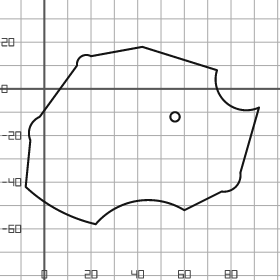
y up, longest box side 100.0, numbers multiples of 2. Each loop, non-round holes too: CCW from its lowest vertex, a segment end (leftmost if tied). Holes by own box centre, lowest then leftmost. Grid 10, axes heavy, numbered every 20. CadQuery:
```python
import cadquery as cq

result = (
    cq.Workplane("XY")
    .moveTo(22.0, -58.0)
    .threePointArc((40.0, -48.0), (60.0, -52.0))
    .lineTo(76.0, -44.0)
    .threePointArc((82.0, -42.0), (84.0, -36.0))
    .lineTo(92.0, -8.0)
    .threePointArc((78.0, -6.0), (74.0, 8.0))
    .lineTo(42.0, 18.0)
    .lineTo(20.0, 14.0)
    .threePointArc((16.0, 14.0), (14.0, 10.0))
    .lineTo(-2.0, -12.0)
    .threePointArc((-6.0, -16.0), (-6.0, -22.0))
    .lineTo(-8.0, -42.0)
    .threePointArc((6.0, -52.0), (22.0, -58.0))
    .close()
    .moveTo(56.0, -12.0)
    .circle(2.0)
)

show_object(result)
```